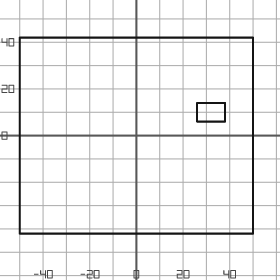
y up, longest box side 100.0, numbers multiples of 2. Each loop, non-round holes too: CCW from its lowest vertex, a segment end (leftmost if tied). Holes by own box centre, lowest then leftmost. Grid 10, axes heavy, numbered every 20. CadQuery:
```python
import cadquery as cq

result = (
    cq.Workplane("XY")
    .moveTo(-50.0, -42.0)
    .lineTo(50.0, -42.0)
    .lineTo(50.0, 42.0)
    .lineTo(-50.0, 42.0)
    .close()
    .moveTo(26.0, 6.0)
    .lineTo(38.0, 6.0)
    .lineTo(38.0, 14.0)
    .lineTo(26.0, 14.0)
    .close()
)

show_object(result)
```